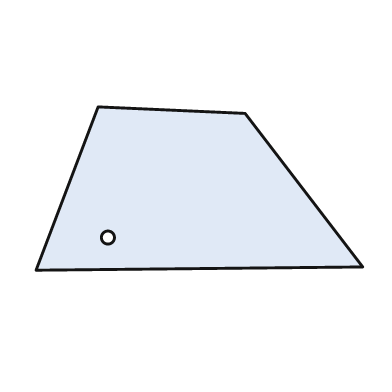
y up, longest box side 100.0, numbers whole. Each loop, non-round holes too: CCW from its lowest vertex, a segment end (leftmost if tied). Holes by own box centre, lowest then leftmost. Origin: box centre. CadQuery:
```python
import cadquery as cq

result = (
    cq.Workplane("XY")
    .moveTo(-50.0, -25.0)
    .lineTo(50.0, -24.0)
    .lineTo(14.0, 23.0)
    .lineTo(-31.0, 25.0)
    .close()
    .moveTo(-28.0, -15.0)
    .circle(2.0)
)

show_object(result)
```